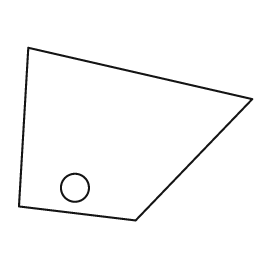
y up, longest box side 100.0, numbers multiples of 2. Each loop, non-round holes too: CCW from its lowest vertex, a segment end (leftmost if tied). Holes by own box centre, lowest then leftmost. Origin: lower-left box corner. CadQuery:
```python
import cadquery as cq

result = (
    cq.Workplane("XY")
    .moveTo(50.0, 0.0)
    .lineTo(100.0, 52.0)
    .lineTo(4.0, 74.0)
    .lineTo(0.0, 6.0)
    .close()
    .moveTo(24.0, 14.0)
    .circle(6.0)
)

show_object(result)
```